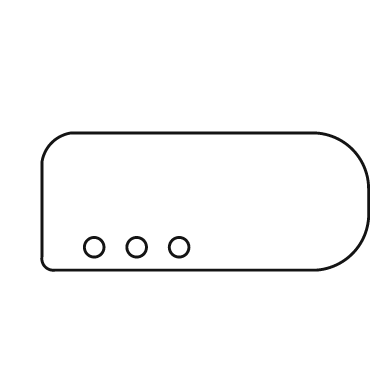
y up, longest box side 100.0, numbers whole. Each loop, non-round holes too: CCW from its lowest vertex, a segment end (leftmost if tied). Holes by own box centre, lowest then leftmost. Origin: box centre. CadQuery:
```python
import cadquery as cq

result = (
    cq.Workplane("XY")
    .moveTo(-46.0, -21.0)
    .lineTo(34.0, -21.0)
    .threePointArc((45.0, -16.0), (50.0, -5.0))
    .lineTo(50.0, 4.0)
    .threePointArc((45.0, 16.0), (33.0, 21.0))
    .lineTo(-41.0, 21.0)
    .threePointArc((-47.0, 18.0), (-50.0, 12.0))
    .lineTo(-50.0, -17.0)
    .threePointArc((-49.0, -20.0), (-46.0, -21.0))
    .close()
    .moveTo(-34.0, -14.0)
    .circle(3.0)
    .moveTo(-21.0, -14.0)
    .circle(3.0)
    .moveTo(-8.0, -14.0)
    .circle(3.0)
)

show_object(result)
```